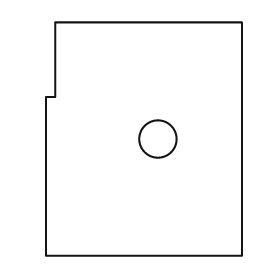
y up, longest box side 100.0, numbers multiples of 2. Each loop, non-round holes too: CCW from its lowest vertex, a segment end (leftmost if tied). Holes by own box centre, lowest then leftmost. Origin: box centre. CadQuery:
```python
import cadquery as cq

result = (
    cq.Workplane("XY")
    .moveTo(-42.0, -50.0)
    .lineTo(42.0, -50.0)
    .lineTo(42.0, 50.0)
    .lineTo(-38.0, 50.0)
    .lineTo(-38.0, 18.0)
    .lineTo(-42.0, 18.0)
    .close()
    .moveTo(6.0, 0.0)
    .circle(8.0)
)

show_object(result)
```